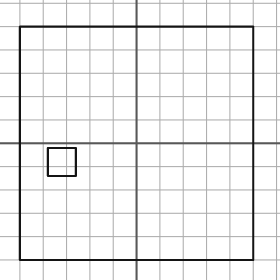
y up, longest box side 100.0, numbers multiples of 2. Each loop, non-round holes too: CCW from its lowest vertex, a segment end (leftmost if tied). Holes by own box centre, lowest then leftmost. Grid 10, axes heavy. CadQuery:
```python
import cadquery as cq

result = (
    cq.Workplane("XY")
    .moveTo(-50.0, -50.0)
    .lineTo(50.0, -50.0)
    .lineTo(50.0, 50.0)
    .lineTo(-50.0, 50.0)
    .close()
    .moveTo(-38.0, -14.0)
    .lineTo(-26.0, -14.0)
    .lineTo(-26.0, -2.0)
    .lineTo(-38.0, -2.0)
    .close()
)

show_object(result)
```